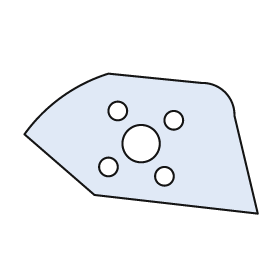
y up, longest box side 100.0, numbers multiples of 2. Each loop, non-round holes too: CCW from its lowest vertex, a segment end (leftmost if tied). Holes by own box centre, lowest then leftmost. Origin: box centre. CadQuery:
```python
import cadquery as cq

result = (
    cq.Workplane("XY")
    .moveTo(50.0, -30.0)
    .lineTo(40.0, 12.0)
    .threePointArc((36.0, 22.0), (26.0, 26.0))
    .lineTo(-14.0, 30.0)
    .threePointArc((-34.0, 20.0), (-50.0, 4.0))
    .lineTo(-20.0, -22.0)
    .close()
    .moveTo(10.0, -14.0)
    .circle(4.0)
    .moveTo(-14.0, -10.0)
    .circle(4.0)
    .moveTo(0.0, 0.0)
    .circle(8.0)
    .moveTo(14.0, 10.0)
    .circle(4.0)
    .moveTo(-10.0, 14.0)
    .circle(4.0)
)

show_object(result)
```